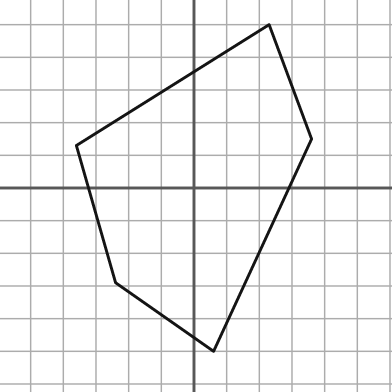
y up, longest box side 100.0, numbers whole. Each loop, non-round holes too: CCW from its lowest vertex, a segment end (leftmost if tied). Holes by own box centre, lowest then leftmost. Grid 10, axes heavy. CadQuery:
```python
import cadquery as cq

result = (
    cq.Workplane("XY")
    .moveTo(6.0, -50.0)
    .lineTo(36.0, 15.0)
    .lineTo(23.0, 50.0)
    .lineTo(-36.0, 13.0)
    .lineTo(-24.0, -29.0)
    .close()
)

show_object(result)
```